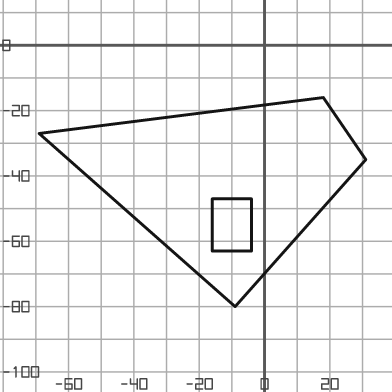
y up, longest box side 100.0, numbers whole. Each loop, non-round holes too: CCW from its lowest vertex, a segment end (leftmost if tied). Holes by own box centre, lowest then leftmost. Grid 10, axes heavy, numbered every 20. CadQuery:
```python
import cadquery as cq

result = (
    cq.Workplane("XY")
    .moveTo(-9.0, -80.0)
    .lineTo(31.0, -35.0)
    .lineTo(18.0, -16.0)
    .lineTo(-69.0, -27.0)
    .close()
    .moveTo(-16.0, -63.0)
    .lineTo(-4.0, -63.0)
    .lineTo(-4.0, -47.0)
    .lineTo(-16.0, -47.0)
    .close()
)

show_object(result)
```